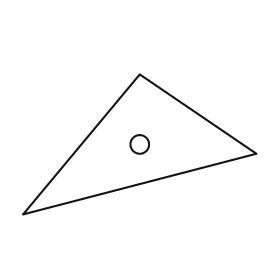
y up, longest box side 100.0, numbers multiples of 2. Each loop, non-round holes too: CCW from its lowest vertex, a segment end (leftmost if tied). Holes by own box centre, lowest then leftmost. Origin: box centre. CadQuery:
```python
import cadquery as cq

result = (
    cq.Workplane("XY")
    .moveTo(-50.0, -30.0)
    .lineTo(50.0, -4.0)
    .lineTo(0.0, 30.0)
    .close()
    .moveTo(0.0, 0.0)
    .circle(4.0)
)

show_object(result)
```